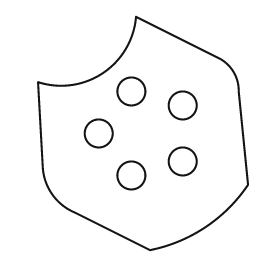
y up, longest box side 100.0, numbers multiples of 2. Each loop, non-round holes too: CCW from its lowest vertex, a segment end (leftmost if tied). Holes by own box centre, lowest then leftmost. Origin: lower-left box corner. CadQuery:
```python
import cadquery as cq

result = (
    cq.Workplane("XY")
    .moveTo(48.0, 0.0)
    .threePointArc((72.0, 10.0), (90.0, 28.0))
    .lineTo(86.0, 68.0)
    .threePointArc((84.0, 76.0), (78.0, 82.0))
    .lineTo(42.0, 100.0)
    .threePointArc((28.0, 76.0), (0.0, 72.0))
    .lineTo(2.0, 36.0)
    .threePointArc((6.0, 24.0), (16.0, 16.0))
    .close()
    .moveTo(40.0, 32.0)
    .circle(6.0)
    .moveTo(62.0, 38.0)
    .circle(6.0)
    .moveTo(26.0, 50.0)
    .circle(6.0)
    .moveTo(62.0, 62.0)
    .circle(6.0)
    .moveTo(40.0, 68.0)
    .circle(6.0)
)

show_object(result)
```